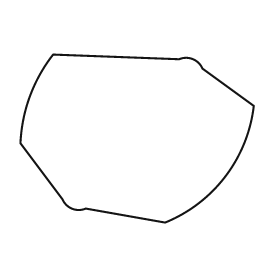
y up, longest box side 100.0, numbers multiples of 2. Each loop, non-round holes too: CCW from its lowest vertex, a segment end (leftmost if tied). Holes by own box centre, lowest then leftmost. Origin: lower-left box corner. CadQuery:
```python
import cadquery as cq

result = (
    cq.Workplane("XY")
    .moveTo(62.0, 0.0)
    .threePointArc((88.0, 20.0), (100.0, 50.0))
    .lineTo(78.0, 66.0)
    .threePointArc((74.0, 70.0), (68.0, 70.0))
    .lineTo(14.0, 72.0)
    .threePointArc((4.0, 54.0), (0.0, 34.0))
    .lineTo(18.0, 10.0)
    .threePointArc((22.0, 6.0), (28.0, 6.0))
    .close()
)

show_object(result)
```